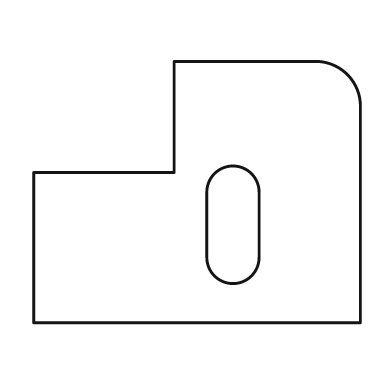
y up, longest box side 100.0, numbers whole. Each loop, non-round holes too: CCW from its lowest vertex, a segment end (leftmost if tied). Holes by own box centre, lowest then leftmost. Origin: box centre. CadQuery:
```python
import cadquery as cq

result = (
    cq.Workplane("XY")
    .moveTo(-50.0, -40.0)
    .lineTo(50.0, -40.0)
    .lineTo(50.0, 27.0)
    .threePointArc((46.0, 36.0), (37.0, 40.0))
    .lineTo(-7.0, 40.0)
    .lineTo(-7.0, 6.0)
    .lineTo(-50.0, 6.0)
    .close()
    .moveTo(3.0, -20.0)
    .threePointArc((11.0, -28.0), (19.0, -20.0))
    .lineTo(19.0, 0.0)
    .threePointArc((11.0, 8.0), (3.0, 0.0))
    .close()
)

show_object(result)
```